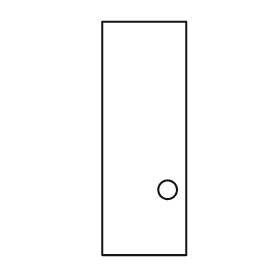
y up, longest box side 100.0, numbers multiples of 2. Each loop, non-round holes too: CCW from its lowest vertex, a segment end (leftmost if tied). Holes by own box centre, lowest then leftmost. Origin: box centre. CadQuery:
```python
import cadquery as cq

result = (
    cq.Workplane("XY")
    .moveTo(-18.0, -50.0)
    .lineTo(18.0, -50.0)
    .lineTo(18.0, 50.0)
    .lineTo(-18.0, 50.0)
    .close()
    .moveTo(10.0, -22.0)
    .circle(4.0)
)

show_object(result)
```